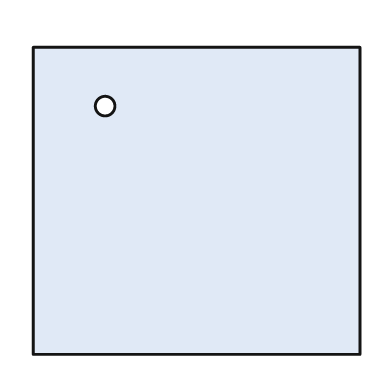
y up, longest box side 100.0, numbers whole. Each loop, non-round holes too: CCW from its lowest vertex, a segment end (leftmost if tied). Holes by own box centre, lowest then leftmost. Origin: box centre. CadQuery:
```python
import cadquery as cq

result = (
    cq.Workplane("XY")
    .moveTo(-50.0, -47.0)
    .lineTo(50.0, -47.0)
    .lineTo(50.0, 47.0)
    .lineTo(-50.0, 47.0)
    .close()
    .moveTo(-28.0, 29.0)
    .circle(3.0)
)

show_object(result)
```